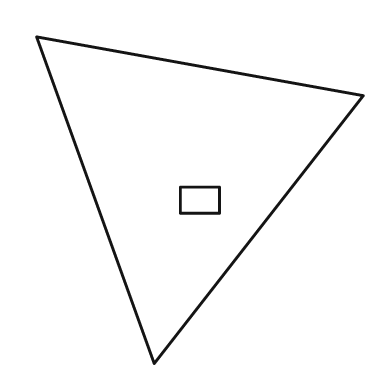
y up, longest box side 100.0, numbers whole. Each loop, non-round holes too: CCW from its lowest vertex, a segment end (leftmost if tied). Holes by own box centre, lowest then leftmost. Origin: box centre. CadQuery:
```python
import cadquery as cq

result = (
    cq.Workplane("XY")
    .moveTo(-14.0, -50.0)
    .lineTo(50.0, 32.0)
    .lineTo(-50.0, 50.0)
    .close()
    .moveTo(-6.0, -4.0)
    .lineTo(6.0, -4.0)
    .lineTo(6.0, 4.0)
    .lineTo(-6.0, 4.0)
    .close()
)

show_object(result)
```